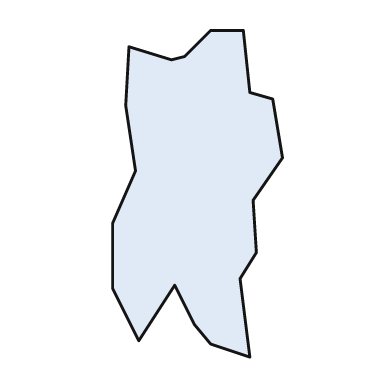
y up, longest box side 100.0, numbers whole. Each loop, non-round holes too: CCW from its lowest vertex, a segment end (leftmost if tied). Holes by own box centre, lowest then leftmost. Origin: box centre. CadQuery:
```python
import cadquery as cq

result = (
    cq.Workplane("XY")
    .moveTo(16.0, -50.0)
    .lineTo(13.0, -26.0)
    .lineTo(18.0, -18.0)
    .lineTo(17.0, -2.0)
    .lineTo(26.0, 11.0)
    .lineTo(23.0, 29.0)
    .lineTo(16.0, 31.0)
    .lineTo(14.0, 50.0)
    .lineTo(4.0, 50.0)
    .lineTo(-4.0, 42.0)
    .lineTo(-8.0, 41.0)
    .lineTo(-21.0, 45.0)
    .lineTo(-22.0, 27.0)
    .lineTo(-19.0, 7.0)
    .lineTo(-26.0, -9.0)
    .lineTo(-26.0, -29.0)
    .lineTo(-18.0, -45.0)
    .lineTo(-7.0, -28.0)
    .lineTo(-1.0, -40.0)
    .lineTo(4.0, -46.0)
    .close()
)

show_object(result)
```